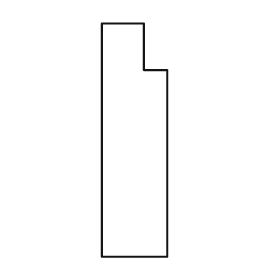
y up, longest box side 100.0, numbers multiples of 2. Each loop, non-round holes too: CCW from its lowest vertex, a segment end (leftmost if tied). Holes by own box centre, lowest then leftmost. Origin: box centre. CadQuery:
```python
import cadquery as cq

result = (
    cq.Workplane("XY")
    .moveTo(-14.0, -50.0)
    .lineTo(14.0, -50.0)
    .lineTo(14.0, 30.0)
    .lineTo(4.0, 30.0)
    .lineTo(4.0, 50.0)
    .lineTo(-14.0, 50.0)
    .close()
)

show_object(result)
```